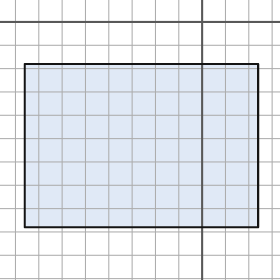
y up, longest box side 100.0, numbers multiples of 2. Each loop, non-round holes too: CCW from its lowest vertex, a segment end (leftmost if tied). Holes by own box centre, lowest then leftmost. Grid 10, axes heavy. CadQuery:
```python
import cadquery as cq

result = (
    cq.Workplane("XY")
    .moveTo(-76.0, -88.0)
    .lineTo(24.0, -88.0)
    .lineTo(24.0, -18.0)
    .lineTo(-76.0, -18.0)
    .close()
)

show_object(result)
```